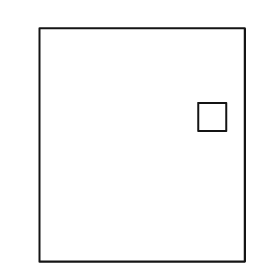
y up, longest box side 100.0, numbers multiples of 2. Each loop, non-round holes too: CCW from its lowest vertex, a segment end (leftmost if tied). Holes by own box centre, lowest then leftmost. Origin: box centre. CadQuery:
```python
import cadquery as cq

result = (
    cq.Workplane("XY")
    .moveTo(-44.0, -50.0)
    .lineTo(44.0, -50.0)
    .lineTo(44.0, 50.0)
    .lineTo(-44.0, 50.0)
    .close()
    .moveTo(24.0, 6.0)
    .lineTo(36.0, 6.0)
    .lineTo(36.0, 18.0)
    .lineTo(24.0, 18.0)
    .close()
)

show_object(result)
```